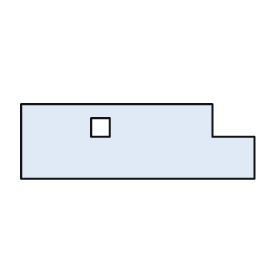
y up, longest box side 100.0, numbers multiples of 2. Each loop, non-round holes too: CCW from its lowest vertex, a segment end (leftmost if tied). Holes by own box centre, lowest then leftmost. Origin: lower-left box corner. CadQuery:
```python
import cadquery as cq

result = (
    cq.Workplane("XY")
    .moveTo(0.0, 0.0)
    .lineTo(100.0, 0.0)
    .lineTo(100.0, 18.0)
    .lineTo(82.0, 18.0)
    .lineTo(82.0, 32.0)
    .lineTo(0.0, 32.0)
    .close()
    .moveTo(30.0, 18.0)
    .lineTo(38.0, 18.0)
    .lineTo(38.0, 26.0)
    .lineTo(30.0, 26.0)
    .close()
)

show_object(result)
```